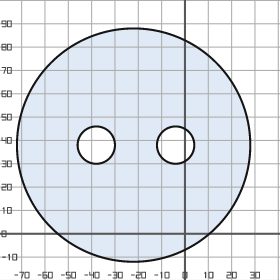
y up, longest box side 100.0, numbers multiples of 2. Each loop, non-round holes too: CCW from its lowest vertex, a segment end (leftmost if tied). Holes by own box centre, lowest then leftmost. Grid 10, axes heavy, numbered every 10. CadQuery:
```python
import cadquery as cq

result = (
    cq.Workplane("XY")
    .moveTo(-22.0, 38.0)
    .circle(50.0)
    .moveTo(-38.0, 38.0)
    .circle(8.0)
    .moveTo(-4.0, 38.0)
    .circle(8.0)
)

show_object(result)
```